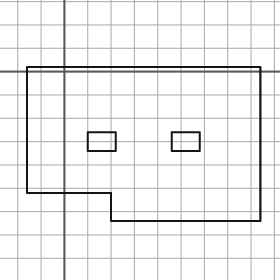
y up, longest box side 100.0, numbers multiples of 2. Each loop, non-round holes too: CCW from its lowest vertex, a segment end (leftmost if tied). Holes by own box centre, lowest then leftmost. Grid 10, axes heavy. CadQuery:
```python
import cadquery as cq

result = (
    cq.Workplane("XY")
    .moveTo(20.0, -64.0)
    .lineTo(84.0, -64.0)
    .lineTo(84.0, 2.0)
    .lineTo(-16.0, 2.0)
    .lineTo(-16.0, -52.0)
    .lineTo(20.0, -52.0)
    .close()
    .moveTo(10.0, -34.0)
    .lineTo(22.0, -34.0)
    .lineTo(22.0, -26.0)
    .lineTo(10.0, -26.0)
    .close()
    .moveTo(46.0, -34.0)
    .lineTo(58.0, -34.0)
    .lineTo(58.0, -26.0)
    .lineTo(46.0, -26.0)
    .close()
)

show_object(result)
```